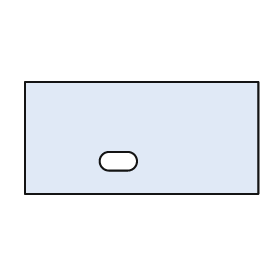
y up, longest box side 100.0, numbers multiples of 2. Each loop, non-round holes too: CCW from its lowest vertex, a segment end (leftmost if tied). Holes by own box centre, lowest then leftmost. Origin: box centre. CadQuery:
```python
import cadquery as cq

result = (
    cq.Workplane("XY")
    .moveTo(-50.0, -24.0)
    .lineTo(50.0, -24.0)
    .lineTo(50.0, 24.0)
    .lineTo(-50.0, 24.0)
    .close()
    .moveTo(-14.0, -14.0)
    .lineTo(-6.0, -14.0)
    .threePointArc((-2.0, -10.0), (-6.0, -6.0))
    .lineTo(-14.0, -6.0)
    .threePointArc((-18.0, -10.0), (-14.0, -14.0))
    .close()
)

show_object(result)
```